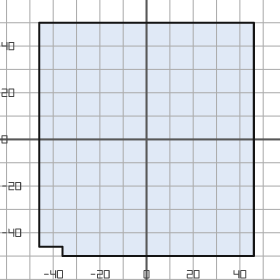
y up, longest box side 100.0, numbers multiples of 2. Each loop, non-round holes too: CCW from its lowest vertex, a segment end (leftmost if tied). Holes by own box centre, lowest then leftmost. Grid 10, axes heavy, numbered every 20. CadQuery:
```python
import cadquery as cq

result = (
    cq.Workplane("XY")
    .moveTo(-36.0, -50.0)
    .lineTo(46.0, -50.0)
    .lineTo(46.0, 50.0)
    .lineTo(-46.0, 50.0)
    .lineTo(-46.0, -46.0)
    .lineTo(-36.0, -46.0)
    .close()
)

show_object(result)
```